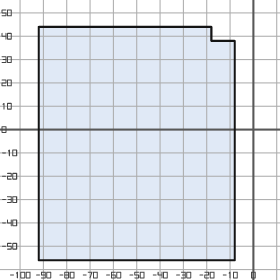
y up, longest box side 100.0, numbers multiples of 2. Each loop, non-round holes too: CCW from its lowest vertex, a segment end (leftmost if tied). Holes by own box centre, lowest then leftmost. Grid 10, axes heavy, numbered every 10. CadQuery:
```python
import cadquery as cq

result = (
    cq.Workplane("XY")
    .moveTo(-92.0, -56.0)
    .lineTo(-8.0, -56.0)
    .lineTo(-8.0, 38.0)
    .lineTo(-18.0, 38.0)
    .lineTo(-18.0, 44.0)
    .lineTo(-92.0, 44.0)
    .close()
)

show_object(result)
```